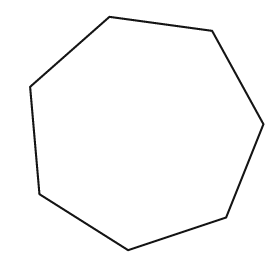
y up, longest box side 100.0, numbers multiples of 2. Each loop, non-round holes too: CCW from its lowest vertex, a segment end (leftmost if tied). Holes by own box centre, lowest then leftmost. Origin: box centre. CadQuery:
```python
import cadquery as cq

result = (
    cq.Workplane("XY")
    .moveTo(-8.0, -50.0)
    .lineTo(34.0, -36.0)
    .lineTo(50.0, 4.0)
    .lineTo(28.0, 44.0)
    .lineTo(-16.0, 50.0)
    .lineTo(-50.0, 20.0)
    .lineTo(-46.0, -26.0)
    .close()
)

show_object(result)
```